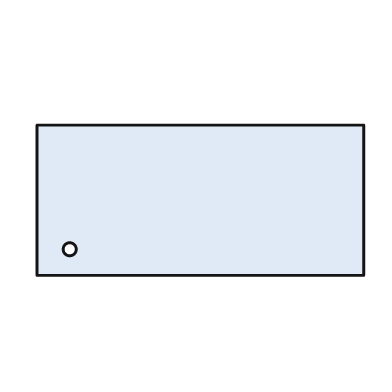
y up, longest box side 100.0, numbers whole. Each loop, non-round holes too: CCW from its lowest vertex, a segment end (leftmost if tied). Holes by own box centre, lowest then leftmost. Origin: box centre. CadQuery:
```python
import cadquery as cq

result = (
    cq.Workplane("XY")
    .moveTo(-50.0, -23.0)
    .lineTo(50.0, -23.0)
    .lineTo(50.0, 23.0)
    .lineTo(-50.0, 23.0)
    .close()
    .moveTo(-40.0, -15.0)
    .circle(2.0)
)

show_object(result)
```